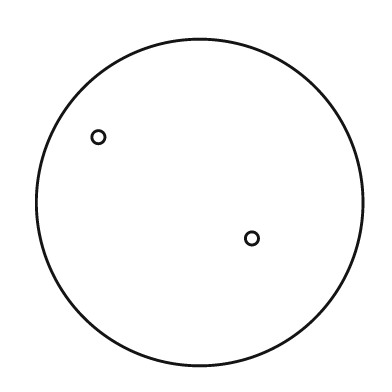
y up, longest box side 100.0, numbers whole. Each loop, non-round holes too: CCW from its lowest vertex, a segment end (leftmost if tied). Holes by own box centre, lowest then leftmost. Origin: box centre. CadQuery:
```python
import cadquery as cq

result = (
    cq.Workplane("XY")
    .moveTo(0.0, 0.0)
    .circle(50.0)
    .moveTo(16.0, -11.0)
    .circle(2.0)
    .moveTo(-31.0, 20.0)
    .circle(2.0)
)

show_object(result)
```